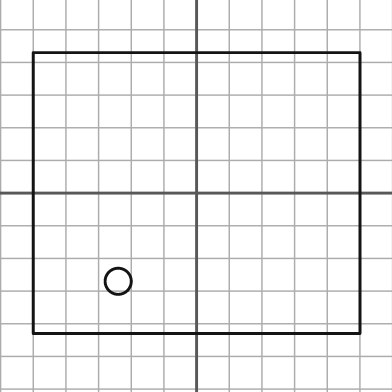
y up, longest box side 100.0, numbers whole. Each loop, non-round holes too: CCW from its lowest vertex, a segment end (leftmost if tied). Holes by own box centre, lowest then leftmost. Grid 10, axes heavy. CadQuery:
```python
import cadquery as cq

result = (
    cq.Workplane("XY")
    .moveTo(-50.0, -43.0)
    .lineTo(50.0, -43.0)
    .lineTo(50.0, 43.0)
    .lineTo(-50.0, 43.0)
    .close()
    .moveTo(-24.0, -27.0)
    .circle(4.0)
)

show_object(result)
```